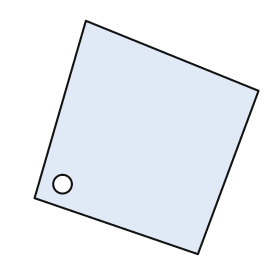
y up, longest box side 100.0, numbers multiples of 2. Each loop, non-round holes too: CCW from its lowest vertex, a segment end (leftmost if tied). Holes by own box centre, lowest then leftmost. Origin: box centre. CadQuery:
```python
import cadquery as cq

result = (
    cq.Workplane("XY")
    .moveTo(22.0, -50.0)
    .lineTo(48.0, 20.0)
    .lineTo(-26.0, 50.0)
    .lineTo(-48.0, -26.0)
    .close()
    .moveTo(-36.0, -20.0)
    .circle(4.0)
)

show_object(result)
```